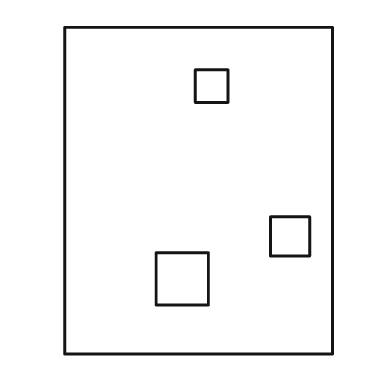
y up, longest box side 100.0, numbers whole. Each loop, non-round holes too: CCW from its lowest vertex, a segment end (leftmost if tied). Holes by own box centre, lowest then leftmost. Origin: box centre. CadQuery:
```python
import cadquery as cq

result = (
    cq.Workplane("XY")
    .moveTo(-41.0, -50.0)
    .lineTo(41.0, -50.0)
    .lineTo(41.0, 50.0)
    .lineTo(-41.0, 50.0)
    .close()
    .moveTo(-13.0, -35.0)
    .lineTo(3.0, -35.0)
    .lineTo(3.0, -19.0)
    .lineTo(-13.0, -19.0)
    .close()
    .moveTo(22.0, -20.0)
    .lineTo(34.0, -20.0)
    .lineTo(34.0, -8.0)
    .lineTo(22.0, -8.0)
    .close()
    .moveTo(-1.0, 27.0)
    .lineTo(9.0, 27.0)
    .lineTo(9.0, 37.0)
    .lineTo(-1.0, 37.0)
    .close()
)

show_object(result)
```